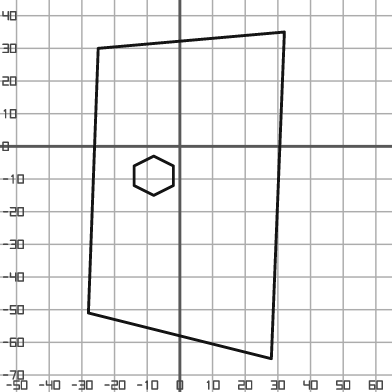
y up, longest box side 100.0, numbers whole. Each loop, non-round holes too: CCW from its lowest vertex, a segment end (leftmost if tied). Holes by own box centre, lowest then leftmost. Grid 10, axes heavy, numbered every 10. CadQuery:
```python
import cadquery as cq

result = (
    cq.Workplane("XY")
    .moveTo(28.0, -65.0)
    .lineTo(32.0, 35.0)
    .lineTo(-25.0, 30.0)
    .lineTo(-28.0, -51.0)
    .close()
    .moveTo(-8.0, -15.0)
    .lineTo(-2.0, -12.0)
    .lineTo(-2.0, -6.0)
    .lineTo(-8.0, -3.0)
    .lineTo(-14.0, -6.0)
    .lineTo(-14.0, -12.0)
    .close()
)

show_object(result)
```